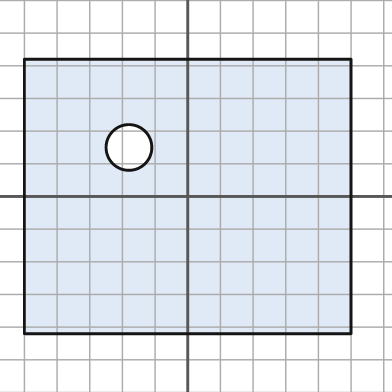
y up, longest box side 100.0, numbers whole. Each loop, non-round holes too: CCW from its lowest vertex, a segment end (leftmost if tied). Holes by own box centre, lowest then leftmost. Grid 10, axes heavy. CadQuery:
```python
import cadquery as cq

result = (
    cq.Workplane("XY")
    .moveTo(-50.0, -42.0)
    .lineTo(50.0, -42.0)
    .lineTo(50.0, 42.0)
    .lineTo(-50.0, 42.0)
    .close()
    .moveTo(-18.0, 15.0)
    .circle(7.0)
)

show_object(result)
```